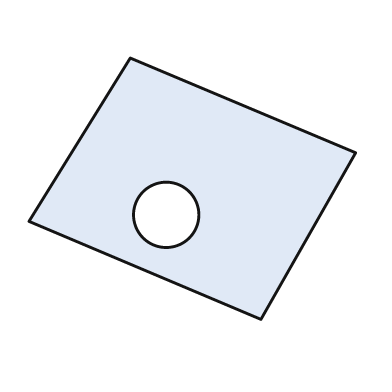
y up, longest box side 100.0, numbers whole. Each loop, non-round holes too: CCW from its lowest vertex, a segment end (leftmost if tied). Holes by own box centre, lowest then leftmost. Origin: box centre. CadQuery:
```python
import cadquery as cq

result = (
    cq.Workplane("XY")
    .moveTo(21.0, -40.0)
    .lineTo(50.0, 11.0)
    .lineTo(-19.0, 40.0)
    .lineTo(-50.0, -10.0)
    .close()
    .moveTo(-8.0, -8.0)
    .circle(10.0)
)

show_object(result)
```